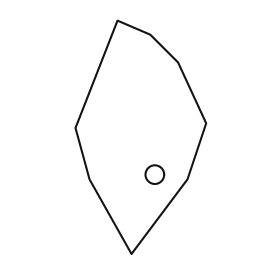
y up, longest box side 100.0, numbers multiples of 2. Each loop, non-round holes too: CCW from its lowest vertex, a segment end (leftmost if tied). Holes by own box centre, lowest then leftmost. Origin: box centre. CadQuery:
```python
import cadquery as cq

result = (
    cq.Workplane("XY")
    .moveTo(-4.0, -50.0)
    .lineTo(20.0, -18.0)
    .lineTo(28.0, 6.0)
    .lineTo(16.0, 32.0)
    .lineTo(4.0, 44.0)
    .lineTo(-10.0, 50.0)
    .lineTo(-28.0, 4.0)
    .lineTo(-22.0, -18.0)
    .close()
    .moveTo(6.0, -16.0)
    .circle(4.0)
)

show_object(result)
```